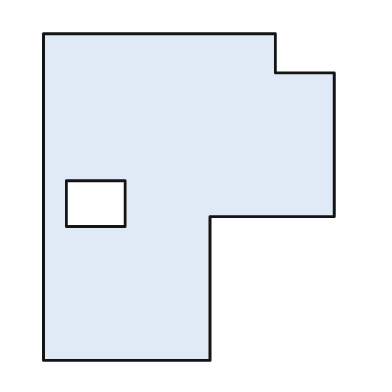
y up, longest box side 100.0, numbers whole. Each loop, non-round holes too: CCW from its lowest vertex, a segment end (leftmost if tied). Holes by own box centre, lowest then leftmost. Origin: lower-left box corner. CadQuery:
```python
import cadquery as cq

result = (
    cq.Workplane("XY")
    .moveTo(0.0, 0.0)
    .lineTo(51.0, 0.0)
    .lineTo(51.0, 44.0)
    .lineTo(89.0, 44.0)
    .lineTo(89.0, 88.0)
    .lineTo(71.0, 88.0)
    .lineTo(71.0, 100.0)
    .lineTo(0.0, 100.0)
    .close()
    .moveTo(7.0, 41.0)
    .lineTo(25.0, 41.0)
    .lineTo(25.0, 55.0)
    .lineTo(7.0, 55.0)
    .close()
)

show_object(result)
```